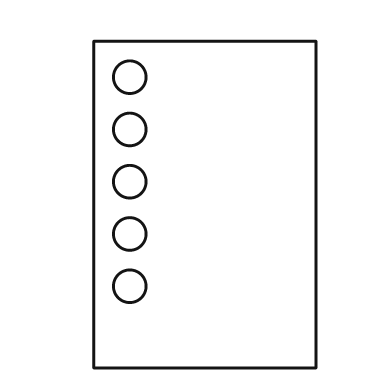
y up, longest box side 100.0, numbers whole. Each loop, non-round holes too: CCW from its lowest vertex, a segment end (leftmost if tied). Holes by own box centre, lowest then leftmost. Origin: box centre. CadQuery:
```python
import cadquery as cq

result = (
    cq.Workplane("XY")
    .moveTo(-34.0, -50.0)
    .lineTo(34.0, -50.0)
    .lineTo(34.0, 50.0)
    .lineTo(-34.0, 50.0)
    .close()
    .moveTo(-23.0, -25.0)
    .circle(5.0)
    .moveTo(-23.0, -9.0)
    .circle(5.0)
    .moveTo(-23.0, 7.0)
    .circle(5.0)
    .moveTo(-23.0, 23.0)
    .circle(5.0)
    .moveTo(-23.0, 39.0)
    .circle(5.0)
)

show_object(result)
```